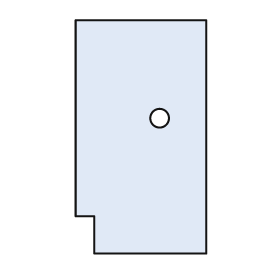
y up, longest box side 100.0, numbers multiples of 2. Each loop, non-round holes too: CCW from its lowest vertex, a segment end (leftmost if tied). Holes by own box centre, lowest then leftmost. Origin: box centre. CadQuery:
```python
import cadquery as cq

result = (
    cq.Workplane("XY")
    .moveTo(-20.0, -50.0)
    .lineTo(28.0, -50.0)
    .lineTo(28.0, 50.0)
    .lineTo(-28.0, 50.0)
    .lineTo(-28.0, -34.0)
    .lineTo(-20.0, -34.0)
    .close()
    .moveTo(8.0, 8.0)
    .circle(4.0)
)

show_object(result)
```